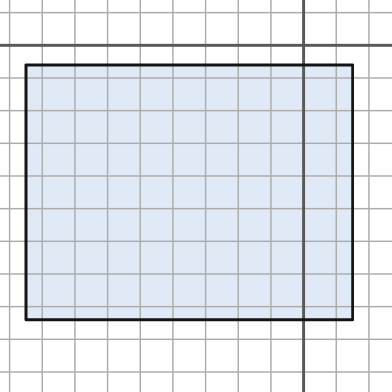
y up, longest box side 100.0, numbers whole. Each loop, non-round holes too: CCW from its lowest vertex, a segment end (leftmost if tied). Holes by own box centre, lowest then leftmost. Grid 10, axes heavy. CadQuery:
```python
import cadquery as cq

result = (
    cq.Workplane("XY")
    .moveTo(-85.0, -84.0)
    .lineTo(15.0, -84.0)
    .lineTo(15.0, -6.0)
    .lineTo(-85.0, -6.0)
    .close()
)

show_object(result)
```